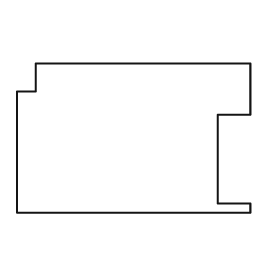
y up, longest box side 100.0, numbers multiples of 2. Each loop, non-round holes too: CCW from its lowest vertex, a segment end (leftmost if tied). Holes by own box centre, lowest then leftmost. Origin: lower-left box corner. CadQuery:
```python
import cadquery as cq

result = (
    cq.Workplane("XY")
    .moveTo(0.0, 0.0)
    .lineTo(100.0, 0.0)
    .lineTo(100.0, 4.0)
    .lineTo(86.0, 4.0)
    .lineTo(86.0, 42.0)
    .lineTo(100.0, 42.0)
    .lineTo(100.0, 64.0)
    .lineTo(8.0, 64.0)
    .lineTo(8.0, 52.0)
    .lineTo(0.0, 52.0)
    .close()
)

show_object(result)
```